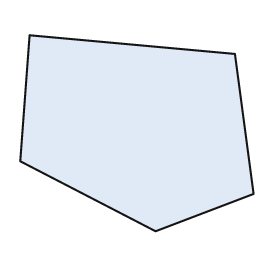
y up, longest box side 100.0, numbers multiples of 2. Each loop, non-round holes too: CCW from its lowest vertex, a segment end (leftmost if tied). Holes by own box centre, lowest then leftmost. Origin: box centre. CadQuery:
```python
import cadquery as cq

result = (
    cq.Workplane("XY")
    .moveTo(8.0, -42.0)
    .lineTo(50.0, -26.0)
    .lineTo(42.0, 34.0)
    .lineTo(-46.0, 42.0)
    .lineTo(-50.0, -12.0)
    .close()
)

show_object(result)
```